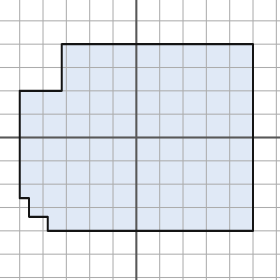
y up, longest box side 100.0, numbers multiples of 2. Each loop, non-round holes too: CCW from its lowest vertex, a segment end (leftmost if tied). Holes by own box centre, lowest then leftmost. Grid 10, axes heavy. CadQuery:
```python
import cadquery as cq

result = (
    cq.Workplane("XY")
    .moveTo(-38.0, -40.0)
    .lineTo(50.0, -40.0)
    .lineTo(50.0, 40.0)
    .lineTo(-32.0, 40.0)
    .lineTo(-32.0, 20.0)
    .lineTo(-50.0, 20.0)
    .lineTo(-50.0, -26.0)
    .lineTo(-46.0, -26.0)
    .lineTo(-46.0, -34.0)
    .lineTo(-38.0, -34.0)
    .close()
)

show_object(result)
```